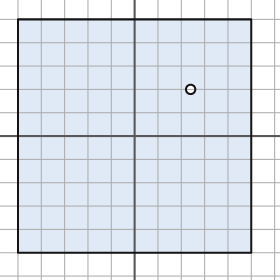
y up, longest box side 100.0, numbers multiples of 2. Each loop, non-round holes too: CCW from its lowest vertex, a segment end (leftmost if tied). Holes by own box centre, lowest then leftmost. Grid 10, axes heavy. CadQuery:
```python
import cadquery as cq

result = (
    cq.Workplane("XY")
    .moveTo(-50.0, -50.0)
    .lineTo(50.0, -50.0)
    .lineTo(50.0, 50.0)
    .lineTo(-50.0, 50.0)
    .close()
    .moveTo(24.0, 20.0)
    .circle(2.0)
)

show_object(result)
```